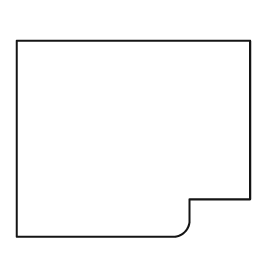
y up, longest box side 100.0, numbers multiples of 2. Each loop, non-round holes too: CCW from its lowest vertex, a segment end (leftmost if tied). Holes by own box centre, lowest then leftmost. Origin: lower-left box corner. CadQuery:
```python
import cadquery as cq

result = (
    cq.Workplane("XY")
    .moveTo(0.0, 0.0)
    .lineTo(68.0, 0.0)
    .threePointArc((72.0, 2.0), (74.0, 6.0))
    .lineTo(74.0, 16.0)
    .lineTo(100.0, 16.0)
    .lineTo(100.0, 84.0)
    .lineTo(0.0, 84.0)
    .close()
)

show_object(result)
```